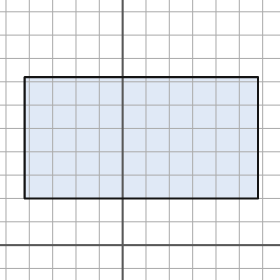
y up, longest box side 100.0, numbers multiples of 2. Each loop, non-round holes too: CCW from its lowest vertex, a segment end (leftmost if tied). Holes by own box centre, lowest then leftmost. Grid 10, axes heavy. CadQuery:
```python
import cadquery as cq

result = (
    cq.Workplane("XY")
    .moveTo(-42.0, 20.0)
    .lineTo(58.0, 20.0)
    .lineTo(58.0, 72.0)
    .lineTo(-42.0, 72.0)
    .close()
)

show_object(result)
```